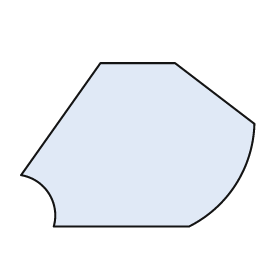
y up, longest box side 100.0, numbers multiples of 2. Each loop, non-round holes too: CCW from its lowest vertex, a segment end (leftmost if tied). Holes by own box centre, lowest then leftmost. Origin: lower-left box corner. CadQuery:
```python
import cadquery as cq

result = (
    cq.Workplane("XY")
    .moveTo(14.0, 0.0)
    .lineTo(72.0, 0.0)
    .threePointArc((92.0, 18.0), (100.0, 44.0))
    .lineTo(66.0, 70.0)
    .lineTo(34.0, 70.0)
    .lineTo(0.0, 22.0)
    .threePointArc((12.0, 14.0), (14.0, 0.0))
    .close()
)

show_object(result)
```